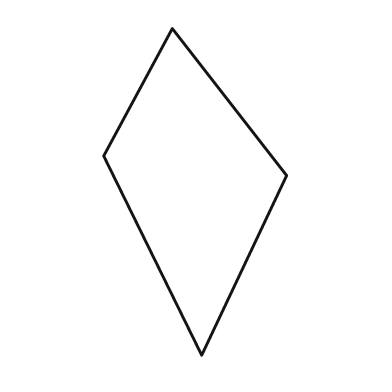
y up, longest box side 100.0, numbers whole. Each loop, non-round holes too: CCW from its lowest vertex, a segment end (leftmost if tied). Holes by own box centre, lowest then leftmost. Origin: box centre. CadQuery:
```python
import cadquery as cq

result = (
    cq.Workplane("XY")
    .moveTo(2.0, -50.0)
    .lineTo(28.0, 5.0)
    .lineTo(-7.0, 50.0)
    .lineTo(-28.0, 11.0)
    .close()
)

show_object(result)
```